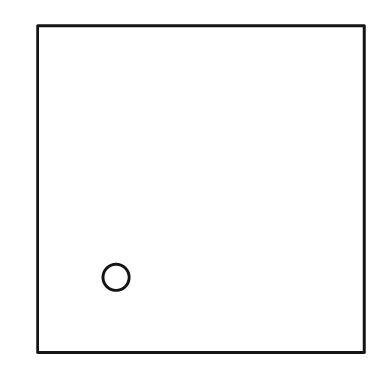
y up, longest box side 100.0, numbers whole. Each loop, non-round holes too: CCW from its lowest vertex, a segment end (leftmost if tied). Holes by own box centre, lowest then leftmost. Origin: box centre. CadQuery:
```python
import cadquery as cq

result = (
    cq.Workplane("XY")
    .moveTo(-50.0, -50.0)
    .lineTo(50.0, -50.0)
    .lineTo(50.0, 50.0)
    .lineTo(-50.0, 50.0)
    .close()
    .moveTo(-26.0, -27.0)
    .circle(4.0)
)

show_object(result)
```